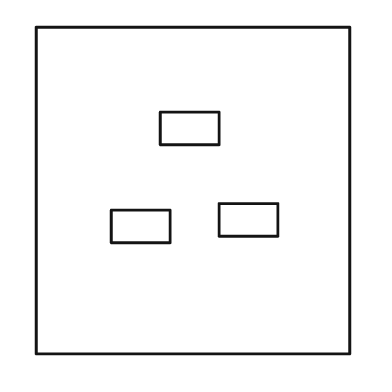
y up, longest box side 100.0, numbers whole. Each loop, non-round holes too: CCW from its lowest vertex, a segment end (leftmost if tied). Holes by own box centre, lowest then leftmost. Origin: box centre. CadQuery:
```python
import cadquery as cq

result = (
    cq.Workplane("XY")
    .moveTo(-48.0, -50.0)
    .lineTo(48.0, -50.0)
    .lineTo(48.0, 50.0)
    .lineTo(-48.0, 50.0)
    .close()
    .moveTo(-25.0, -16.0)
    .lineTo(-7.0, -16.0)
    .lineTo(-7.0, -6.0)
    .lineTo(-25.0, -6.0)
    .close()
    .moveTo(8.0, -14.0)
    .lineTo(26.0, -14.0)
    .lineTo(26.0, -4.0)
    .lineTo(8.0, -4.0)
    .close()
    .moveTo(-10.0, 14.0)
    .lineTo(8.0, 14.0)
    .lineTo(8.0, 24.0)
    .lineTo(-10.0, 24.0)
    .close()
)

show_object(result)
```